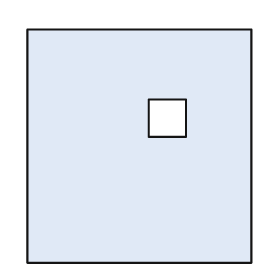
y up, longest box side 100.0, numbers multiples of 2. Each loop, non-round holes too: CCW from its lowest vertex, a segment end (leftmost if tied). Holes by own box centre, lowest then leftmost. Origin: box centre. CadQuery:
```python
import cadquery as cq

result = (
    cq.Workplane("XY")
    .moveTo(-48.0, -50.0)
    .lineTo(48.0, -50.0)
    .lineTo(48.0, 50.0)
    .lineTo(-48.0, 50.0)
    .close()
    .moveTo(4.0, 4.0)
    .lineTo(20.0, 4.0)
    .lineTo(20.0, 20.0)
    .lineTo(4.0, 20.0)
    .close()
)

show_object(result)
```